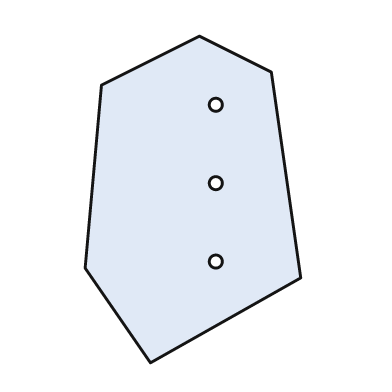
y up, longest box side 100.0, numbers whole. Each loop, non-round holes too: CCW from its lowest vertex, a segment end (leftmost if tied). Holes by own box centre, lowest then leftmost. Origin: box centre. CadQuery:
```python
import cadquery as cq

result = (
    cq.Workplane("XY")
    .moveTo(-13.0, -50.0)
    .lineTo(33.0, -24.0)
    .lineTo(24.0, 39.0)
    .lineTo(2.0, 50.0)
    .lineTo(-28.0, 35.0)
    .lineTo(-33.0, -21.0)
    .close()
    .moveTo(7.0, -19.0)
    .circle(2.0)
    .moveTo(7.0, 5.0)
    .circle(2.0)
    .moveTo(7.0, 29.0)
    .circle(2.0)
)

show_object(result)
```